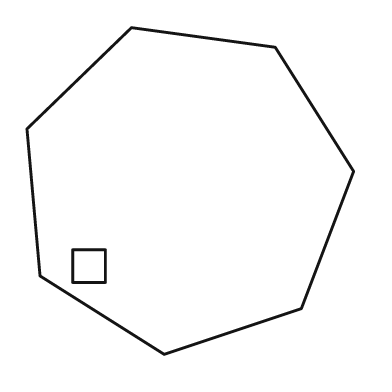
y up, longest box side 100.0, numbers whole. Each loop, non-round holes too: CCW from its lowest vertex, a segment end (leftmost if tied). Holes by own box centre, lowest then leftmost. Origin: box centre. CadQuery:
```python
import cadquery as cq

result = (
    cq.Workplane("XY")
    .moveTo(-8.0, -50.0)
    .lineTo(34.0, -36.0)
    .lineTo(50.0, 6.0)
    .lineTo(26.0, 44.0)
    .lineTo(-18.0, 50.0)
    .lineTo(-50.0, 19.0)
    .lineTo(-46.0, -26.0)
    .close()
    .moveTo(-36.0, -28.0)
    .lineTo(-26.0, -28.0)
    .lineTo(-26.0, -18.0)
    .lineTo(-36.0, -18.0)
    .close()
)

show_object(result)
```